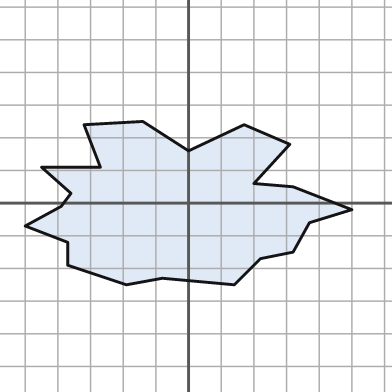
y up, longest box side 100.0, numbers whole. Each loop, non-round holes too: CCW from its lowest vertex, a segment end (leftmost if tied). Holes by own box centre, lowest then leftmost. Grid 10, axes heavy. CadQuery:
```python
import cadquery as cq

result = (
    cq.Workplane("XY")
    .moveTo(-19.0, -25.0)
    .lineTo(-8.0, -23.0)
    .lineTo(14.0, -25.0)
    .lineTo(22.0, -17.0)
    .lineTo(32.0, -15.0)
    .lineTo(37.0, -6.0)
    .lineTo(50.0, -2.0)
    .lineTo(32.0, 5.0)
    .lineTo(20.0, 6.0)
    .lineTo(31.0, 18.0)
    .lineTo(17.0, 24.0)
    .lineTo(0.0, 16.0)
    .lineTo(-14.0, 25.0)
    .lineTo(-32.0, 24.0)
    .lineTo(-27.0, 11.0)
    .lineTo(-45.0, 11.0)
    .lineTo(-36.0, 3.0)
    .lineTo(-39.0, -1.0)
    .lineTo(-50.0, -7.0)
    .lineTo(-37.0, -12.0)
    .lineTo(-37.0, -19.0)
    .close()
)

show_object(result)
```